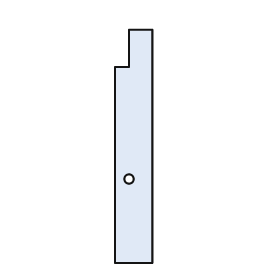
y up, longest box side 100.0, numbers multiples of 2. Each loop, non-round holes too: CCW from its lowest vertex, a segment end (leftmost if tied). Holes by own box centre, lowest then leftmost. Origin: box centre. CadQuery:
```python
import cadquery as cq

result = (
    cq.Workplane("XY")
    .moveTo(-8.0, -50.0)
    .lineTo(8.0, -50.0)
    .lineTo(8.0, 50.0)
    .lineTo(-2.0, 50.0)
    .lineTo(-2.0, 34.0)
    .lineTo(-8.0, 34.0)
    .close()
    .moveTo(-2.0, -14.0)
    .circle(2.0)
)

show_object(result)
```